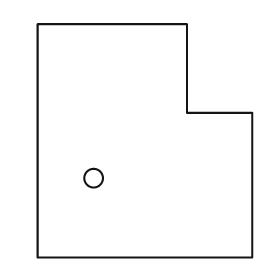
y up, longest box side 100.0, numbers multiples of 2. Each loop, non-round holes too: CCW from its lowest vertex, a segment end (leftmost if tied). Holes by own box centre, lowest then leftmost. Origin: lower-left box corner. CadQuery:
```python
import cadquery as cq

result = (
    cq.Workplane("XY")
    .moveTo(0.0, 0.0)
    .lineTo(92.0, 0.0)
    .lineTo(92.0, 62.0)
    .lineTo(64.0, 62.0)
    .lineTo(64.0, 100.0)
    .lineTo(0.0, 100.0)
    .close()
    .moveTo(24.0, 34.0)
    .circle(4.0)
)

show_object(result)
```